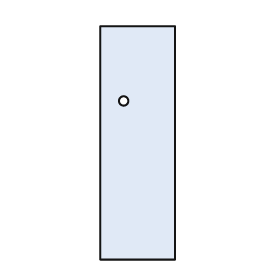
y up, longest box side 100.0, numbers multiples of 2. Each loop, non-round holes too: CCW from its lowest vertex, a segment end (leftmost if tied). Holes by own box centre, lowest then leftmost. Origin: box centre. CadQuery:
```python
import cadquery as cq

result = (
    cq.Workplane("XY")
    .moveTo(-16.0, -50.0)
    .lineTo(16.0, -50.0)
    .lineTo(16.0, 50.0)
    .lineTo(-16.0, 50.0)
    .close()
    .moveTo(-6.0, 18.0)
    .circle(2.0)
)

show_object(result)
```